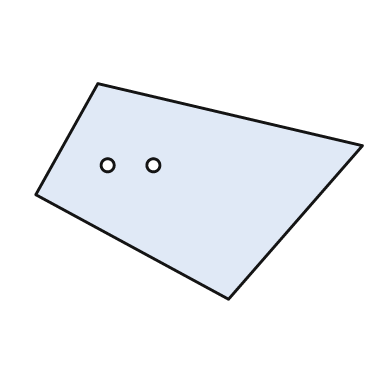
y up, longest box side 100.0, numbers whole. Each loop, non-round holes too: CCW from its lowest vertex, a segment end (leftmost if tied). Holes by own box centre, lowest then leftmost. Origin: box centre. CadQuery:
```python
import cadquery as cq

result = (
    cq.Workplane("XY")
    .moveTo(9.0, -33.0)
    .lineTo(50.0, 14.0)
    .lineTo(-31.0, 33.0)
    .lineTo(-50.0, -1.0)
    .close()
    .moveTo(-28.0, 8.0)
    .circle(2.0)
    .moveTo(-14.0, 8.0)
    .circle(2.0)
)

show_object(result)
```